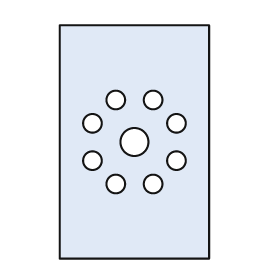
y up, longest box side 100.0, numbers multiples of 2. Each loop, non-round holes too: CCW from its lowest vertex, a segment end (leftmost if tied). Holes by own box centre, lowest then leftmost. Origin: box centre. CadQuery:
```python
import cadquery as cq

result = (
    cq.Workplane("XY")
    .moveTo(-32.0, -50.0)
    .lineTo(32.0, -50.0)
    .lineTo(32.0, 50.0)
    .lineTo(-32.0, 50.0)
    .close()
    .moveTo(-8.0, -18.0)
    .circle(4.0)
    .moveTo(8.0, -18.0)
    .circle(4.0)
    .moveTo(-18.0, -8.0)
    .circle(4.0)
    .moveTo(18.0, -8.0)
    .circle(4.0)
    .moveTo(0.0, 0.0)
    .circle(6.0)
    .moveTo(-18.0, 8.0)
    .circle(4.0)
    .moveTo(18.0, 8.0)
    .circle(4.0)
    .moveTo(-8.0, 18.0)
    .circle(4.0)
    .moveTo(8.0, 18.0)
    .circle(4.0)
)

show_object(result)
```